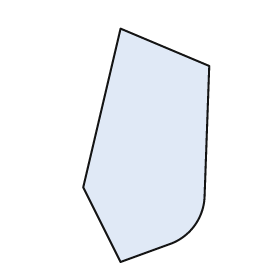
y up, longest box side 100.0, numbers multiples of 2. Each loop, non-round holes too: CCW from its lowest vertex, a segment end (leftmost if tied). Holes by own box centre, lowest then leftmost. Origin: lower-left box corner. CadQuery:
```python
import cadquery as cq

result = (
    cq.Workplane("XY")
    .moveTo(16.0, 0.0)
    .lineTo(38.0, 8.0)
    .threePointArc((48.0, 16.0), (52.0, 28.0))
    .lineTo(54.0, 84.0)
    .lineTo(16.0, 100.0)
    .lineTo(0.0, 32.0)
    .close()
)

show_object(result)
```